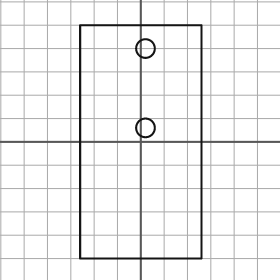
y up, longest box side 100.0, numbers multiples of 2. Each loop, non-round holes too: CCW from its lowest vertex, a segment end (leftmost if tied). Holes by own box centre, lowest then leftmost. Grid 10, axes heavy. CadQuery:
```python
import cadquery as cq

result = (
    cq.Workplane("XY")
    .moveTo(-26.0, -50.0)
    .lineTo(26.0, -50.0)
    .lineTo(26.0, 50.0)
    .lineTo(-26.0, 50.0)
    .close()
    .moveTo(2.0, 6.0)
    .circle(4.0)
    .moveTo(2.0, 40.0)
    .circle(4.0)
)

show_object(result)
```